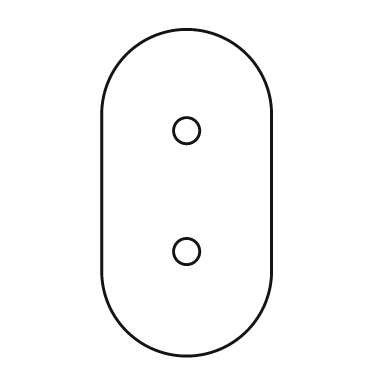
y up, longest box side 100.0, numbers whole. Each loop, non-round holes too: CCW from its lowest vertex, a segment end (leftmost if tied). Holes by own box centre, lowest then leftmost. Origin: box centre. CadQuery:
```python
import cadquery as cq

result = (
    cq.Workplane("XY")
    .moveTo(-26.0, -24.0)
    .threePointArc((0.0, -50.0), (26.0, -24.0))
    .lineTo(26.0, 24.0)
    .threePointArc((0.0, 50.0), (-26.0, 24.0))
    .close()
    .moveTo(0.0, -18.0)
    .circle(4.0)
    .moveTo(0.0, 19.0)
    .circle(4.0)
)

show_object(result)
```